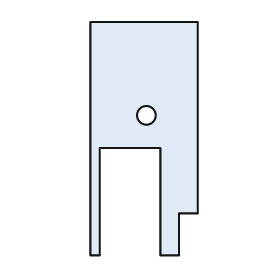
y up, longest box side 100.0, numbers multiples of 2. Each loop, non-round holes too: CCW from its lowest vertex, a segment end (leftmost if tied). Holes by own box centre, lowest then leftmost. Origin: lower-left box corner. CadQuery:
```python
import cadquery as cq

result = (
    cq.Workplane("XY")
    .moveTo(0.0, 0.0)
    .lineTo(4.0, 0.0)
    .lineTo(4.0, 46.0)
    .lineTo(30.0, 46.0)
    .lineTo(30.0, 0.0)
    .lineTo(38.0, 0.0)
    .lineTo(38.0, 18.0)
    .lineTo(46.0, 18.0)
    .lineTo(46.0, 100.0)
    .lineTo(0.0, 100.0)
    .close()
    .moveTo(24.0, 60.0)
    .circle(4.0)
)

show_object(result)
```